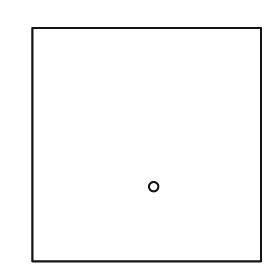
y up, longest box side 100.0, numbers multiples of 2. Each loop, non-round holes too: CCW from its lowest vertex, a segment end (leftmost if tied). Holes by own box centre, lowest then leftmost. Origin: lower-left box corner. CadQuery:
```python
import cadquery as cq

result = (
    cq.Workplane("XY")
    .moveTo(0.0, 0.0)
    .lineTo(98.0, 0.0)
    .lineTo(98.0, 100.0)
    .lineTo(0.0, 100.0)
    .close()
    .moveTo(52.0, 32.0)
    .circle(2.0)
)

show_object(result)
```